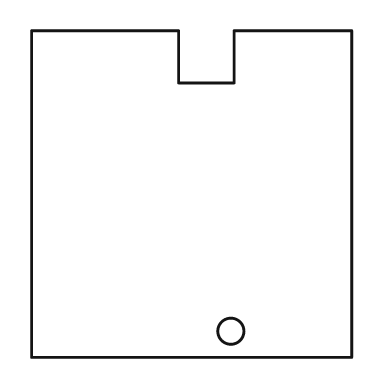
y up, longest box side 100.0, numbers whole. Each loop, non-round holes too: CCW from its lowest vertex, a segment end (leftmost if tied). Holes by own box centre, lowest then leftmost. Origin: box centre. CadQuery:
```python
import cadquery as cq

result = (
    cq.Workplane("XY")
    .moveTo(-49.0, -50.0)
    .lineTo(49.0, -50.0)
    .lineTo(49.0, 50.0)
    .lineTo(13.0, 50.0)
    .lineTo(13.0, 34.0)
    .lineTo(-4.0, 34.0)
    .lineTo(-4.0, 50.0)
    .lineTo(-49.0, 50.0)
    .close()
    .moveTo(12.0, -42.0)
    .circle(4.0)
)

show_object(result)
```